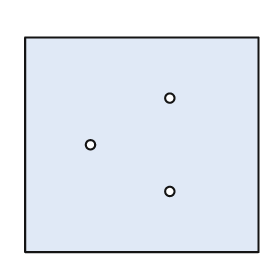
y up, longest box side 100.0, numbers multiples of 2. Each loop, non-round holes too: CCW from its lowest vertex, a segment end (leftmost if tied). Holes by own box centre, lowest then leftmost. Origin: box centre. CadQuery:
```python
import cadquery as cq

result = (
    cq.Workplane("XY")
    .moveTo(-50.0, -46.0)
    .lineTo(50.0, -46.0)
    .lineTo(50.0, 46.0)
    .lineTo(-50.0, 46.0)
    .close()
    .moveTo(12.0, -20.0)
    .circle(2.0)
    .moveTo(-22.0, 0.0)
    .circle(2.0)
    .moveTo(12.0, 20.0)
    .circle(2.0)
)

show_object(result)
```